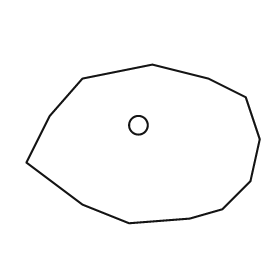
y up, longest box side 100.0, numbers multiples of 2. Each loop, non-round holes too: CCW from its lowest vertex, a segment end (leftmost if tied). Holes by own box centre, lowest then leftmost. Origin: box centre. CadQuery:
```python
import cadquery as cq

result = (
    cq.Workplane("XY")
    .moveTo(-6.0, -34.0)
    .lineTo(20.0, -32.0)
    .lineTo(34.0, -28.0)
    .lineTo(46.0, -16.0)
    .lineTo(50.0, 2.0)
    .lineTo(44.0, 20.0)
    .lineTo(28.0, 28.0)
    .lineTo(4.0, 34.0)
    .lineTo(-26.0, 28.0)
    .lineTo(-40.0, 12.0)
    .lineTo(-50.0, -8.0)
    .lineTo(-26.0, -26.0)
    .close()
    .moveTo(-2.0, 8.0)
    .circle(4.0)
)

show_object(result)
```